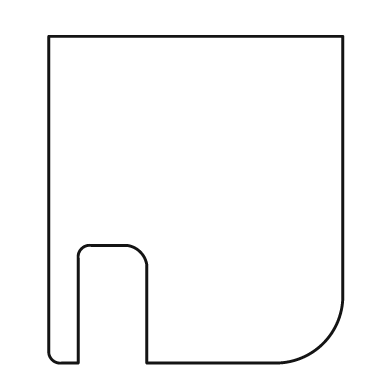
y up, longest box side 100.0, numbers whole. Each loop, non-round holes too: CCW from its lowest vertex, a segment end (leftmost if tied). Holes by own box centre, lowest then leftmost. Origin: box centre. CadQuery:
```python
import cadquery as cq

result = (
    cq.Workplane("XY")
    .moveTo(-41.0, -50.0)
    .lineTo(-36.0, -50.0)
    .lineTo(-36.0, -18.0)
    .threePointArc((-35.0, -15.0), (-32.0, -14.0))
    .lineTo(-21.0, -14.0)
    .threePointArc((-17.0, -16.0), (-15.0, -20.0))
    .lineTo(-15.0, -50.0)
    .lineTo(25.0, -50.0)
    .threePointArc((39.0, -44.0), (45.0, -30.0))
    .lineTo(45.0, 50.0)
    .lineTo(-45.0, 50.0)
    .lineTo(-45.0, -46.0)
    .threePointArc((-44.0, -49.0), (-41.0, -50.0))
    .close()
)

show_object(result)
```